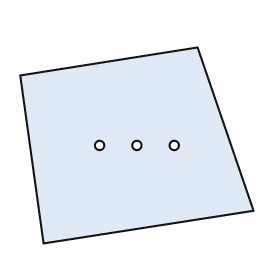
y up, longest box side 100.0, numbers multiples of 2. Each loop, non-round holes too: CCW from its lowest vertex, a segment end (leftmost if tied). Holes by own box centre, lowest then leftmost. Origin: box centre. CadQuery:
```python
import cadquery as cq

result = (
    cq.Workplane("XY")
    .moveTo(-40.0, -42.0)
    .lineTo(50.0, -28.0)
    .lineTo(26.0, 42.0)
    .lineTo(-50.0, 30.0)
    .close()
    .moveTo(-16.0, 0.0)
    .circle(2.0)
    .moveTo(0.0, 0.0)
    .circle(2.0)
    .moveTo(16.0, 0.0)
    .circle(2.0)
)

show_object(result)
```